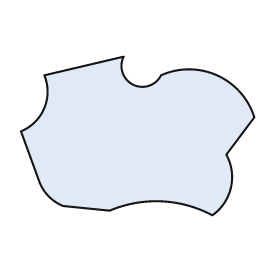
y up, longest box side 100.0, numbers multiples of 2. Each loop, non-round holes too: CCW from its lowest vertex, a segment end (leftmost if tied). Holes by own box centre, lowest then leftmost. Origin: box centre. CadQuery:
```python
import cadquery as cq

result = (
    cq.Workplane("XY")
    .moveTo(32.0, -34.0)
    .threePointArc((40.0, -22.0), (38.0, -8.0))
    .lineTo(50.0, 8.0)
    .threePointArc((34.0, 26.0), (10.0, 26.0))
    .threePointArc((-2.0, 22.0), (-6.0, 34.0))
    .lineTo(-40.0, 26.0)
    .threePointArc((-40.0, 12.0), (-50.0, 2.0))
    .lineTo(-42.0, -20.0)
    .threePointArc((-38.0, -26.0), (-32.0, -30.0))
    .lineTo(-12.0, -32.0)
    .threePointArc((10.0, -28.0), (32.0, -34.0))
    .close()
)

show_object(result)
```